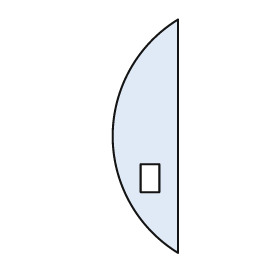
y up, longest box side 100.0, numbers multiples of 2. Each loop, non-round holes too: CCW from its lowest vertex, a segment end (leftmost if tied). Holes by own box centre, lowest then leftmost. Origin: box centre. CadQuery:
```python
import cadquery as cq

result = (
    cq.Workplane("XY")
    .moveTo(14.0, -50.0)
    .lineTo(14.0, 50.0)
    .threePointArc((-14.0, 0.0), (14.0, -50.0))
    .close()
    .moveTo(-2.0, -24.0)
    .lineTo(6.0, -24.0)
    .lineTo(6.0, -12.0)
    .lineTo(-2.0, -12.0)
    .close()
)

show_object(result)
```